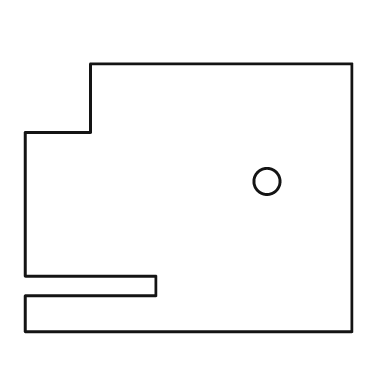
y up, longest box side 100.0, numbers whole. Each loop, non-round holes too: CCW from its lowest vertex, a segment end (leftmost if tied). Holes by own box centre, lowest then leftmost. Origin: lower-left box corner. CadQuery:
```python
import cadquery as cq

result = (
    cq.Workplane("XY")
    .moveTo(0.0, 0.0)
    .lineTo(100.0, 0.0)
    .lineTo(100.0, 82.0)
    .lineTo(20.0, 82.0)
    .lineTo(20.0, 61.0)
    .lineTo(0.0, 61.0)
    .lineTo(0.0, 17.0)
    .lineTo(40.0, 17.0)
    .lineTo(40.0, 11.0)
    .lineTo(0.0, 11.0)
    .close()
    .moveTo(74.0, 46.0)
    .circle(4.0)
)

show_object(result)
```